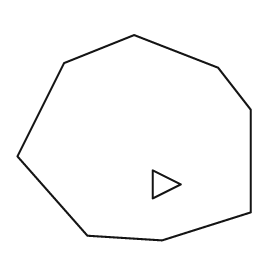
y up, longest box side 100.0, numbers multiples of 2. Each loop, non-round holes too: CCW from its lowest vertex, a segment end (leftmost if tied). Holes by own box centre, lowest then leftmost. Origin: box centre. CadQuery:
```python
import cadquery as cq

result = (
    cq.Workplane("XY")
    .moveTo(12.0, -44.0)
    .lineTo(50.0, -32.0)
    .lineTo(50.0, 12.0)
    .lineTo(36.0, 30.0)
    .lineTo(0.0, 44.0)
    .lineTo(-30.0, 32.0)
    .lineTo(-50.0, -8.0)
    .lineTo(-20.0, -42.0)
    .close()
    .moveTo(8.0, -26.0)
    .lineTo(20.0, -20.0)
    .lineTo(8.0, -14.0)
    .close()
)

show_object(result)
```